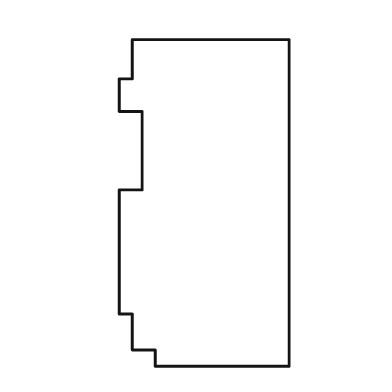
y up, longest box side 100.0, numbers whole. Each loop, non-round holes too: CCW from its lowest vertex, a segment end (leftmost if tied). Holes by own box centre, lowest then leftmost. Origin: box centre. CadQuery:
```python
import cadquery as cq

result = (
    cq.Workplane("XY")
    .moveTo(-15.0, -50.0)
    .lineTo(26.0, -50.0)
    .lineTo(26.0, 50.0)
    .lineTo(-22.0, 50.0)
    .lineTo(-22.0, 38.0)
    .lineTo(-26.0, 38.0)
    .lineTo(-26.0, 28.0)
    .lineTo(-19.0, 28.0)
    .lineTo(-19.0, 4.0)
    .lineTo(-26.0, 4.0)
    .lineTo(-26.0, -34.0)
    .lineTo(-22.0, -34.0)
    .lineTo(-22.0, -45.0)
    .lineTo(-15.0, -45.0)
    .close()
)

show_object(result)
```